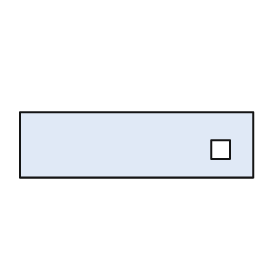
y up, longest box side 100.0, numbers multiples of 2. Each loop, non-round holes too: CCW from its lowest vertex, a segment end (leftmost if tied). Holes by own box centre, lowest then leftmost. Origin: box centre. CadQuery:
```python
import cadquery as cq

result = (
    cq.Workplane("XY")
    .moveTo(-50.0, -14.0)
    .lineTo(50.0, -14.0)
    .lineTo(50.0, 14.0)
    .lineTo(-50.0, 14.0)
    .close()
    .moveTo(32.0, -6.0)
    .lineTo(40.0, -6.0)
    .lineTo(40.0, 2.0)
    .lineTo(32.0, 2.0)
    .close()
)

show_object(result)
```